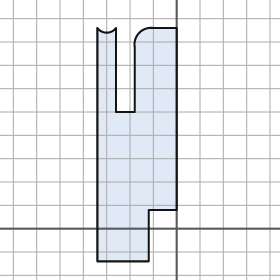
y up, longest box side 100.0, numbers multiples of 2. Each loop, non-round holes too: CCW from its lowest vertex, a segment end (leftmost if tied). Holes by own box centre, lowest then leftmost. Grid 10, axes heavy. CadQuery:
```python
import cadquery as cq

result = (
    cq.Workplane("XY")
    .moveTo(-34.0, -14.0)
    .lineTo(-12.0, -14.0)
    .lineTo(-12.0, 8.0)
    .lineTo(0.0, 8.0)
    .lineTo(0.0, 86.0)
    .lineTo(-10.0, 86.0)
    .threePointArc((-16.0, 84.0), (-18.0, 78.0))
    .lineTo(-18.0, 50.0)
    .lineTo(-26.0, 50.0)
    .lineTo(-26.0, 86.0)
    .threePointArc((-30.0, 84.0), (-34.0, 86.0))
    .close()
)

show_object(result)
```